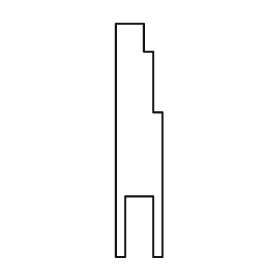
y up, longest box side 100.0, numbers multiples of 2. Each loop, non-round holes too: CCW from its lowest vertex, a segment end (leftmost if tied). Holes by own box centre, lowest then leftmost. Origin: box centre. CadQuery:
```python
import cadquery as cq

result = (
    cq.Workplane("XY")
    .moveTo(-10.0, -50.0)
    .lineTo(-6.0, -50.0)
    .lineTo(-6.0, -24.0)
    .lineTo(6.0, -24.0)
    .lineTo(6.0, -50.0)
    .lineTo(10.0, -50.0)
    .lineTo(10.0, 12.0)
    .lineTo(6.0, 12.0)
    .lineTo(6.0, 38.0)
    .lineTo(2.0, 38.0)
    .lineTo(2.0, 50.0)
    .lineTo(-10.0, 50.0)
    .close()
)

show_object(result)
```